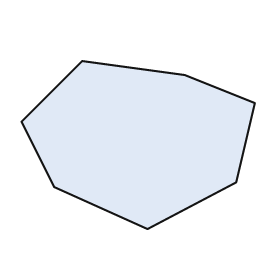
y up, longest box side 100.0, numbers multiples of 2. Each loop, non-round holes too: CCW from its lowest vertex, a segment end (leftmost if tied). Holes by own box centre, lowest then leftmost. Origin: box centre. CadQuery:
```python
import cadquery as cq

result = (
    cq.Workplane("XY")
    .moveTo(4.0, -36.0)
    .lineTo(42.0, -16.0)
    .lineTo(50.0, 18.0)
    .lineTo(20.0, 30.0)
    .lineTo(-24.0, 36.0)
    .lineTo(-50.0, 10.0)
    .lineTo(-36.0, -18.0)
    .close()
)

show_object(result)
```